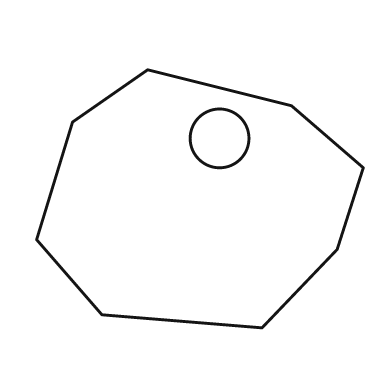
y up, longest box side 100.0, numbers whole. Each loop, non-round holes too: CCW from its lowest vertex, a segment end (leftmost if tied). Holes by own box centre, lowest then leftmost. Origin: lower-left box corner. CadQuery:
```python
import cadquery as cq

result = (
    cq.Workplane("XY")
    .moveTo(69.0, 0.0)
    .lineTo(92.0, 24.0)
    .lineTo(100.0, 49.0)
    .lineTo(78.0, 68.0)
    .lineTo(34.0, 79.0)
    .lineTo(11.0, 63.0)
    .lineTo(0.0, 27.0)
    .lineTo(20.0, 4.0)
    .close()
    .moveTo(56.0, 58.0)
    .circle(9.0)
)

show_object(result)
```